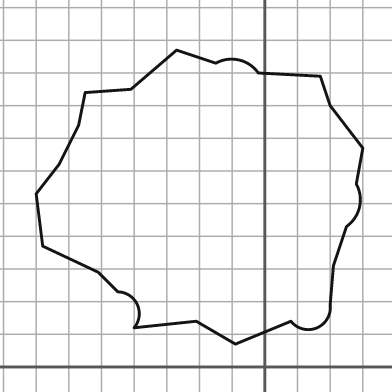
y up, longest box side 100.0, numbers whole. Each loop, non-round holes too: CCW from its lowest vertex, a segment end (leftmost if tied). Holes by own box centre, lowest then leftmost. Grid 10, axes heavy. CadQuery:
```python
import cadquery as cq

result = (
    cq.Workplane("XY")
    .moveTo(-9.0, 7.0)
    .lineTo(8.0, 14.0)
    .threePointArc((16.0, 12.0), (20.0, 19.0))
    .lineTo(21.0, 31.0)
    .lineTo(25.0, 43.0)
    .threePointArc((29.0, 49.0), (28.0, 56.0))
    .lineTo(30.0, 67.0)
    .lineTo(20.0, 80.0)
    .lineTo(17.0, 89.0)
    .lineTo(-2.0, 90.0)
    .threePointArc((-8.0, 94.0), (-15.0, 93.0))
    .lineTo(-27.0, 97.0)
    .lineTo(-41.0, 85.0)
    .lineTo(-55.0, 84.0)
    .lineTo(-57.0, 74.0)
    .lineTo(-63.0, 62.0)
    .lineTo(-70.0, 53.0)
    .lineTo(-68.0, 37.0)
    .lineTo(-51.0, 29.0)
    .lineTo(-45.0, 23.0)
    .threePointArc((-39.0, 19.0), (-40.0, 12.0))
    .lineTo(-21.0, 14.0)
    .close()
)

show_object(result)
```